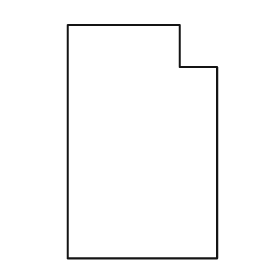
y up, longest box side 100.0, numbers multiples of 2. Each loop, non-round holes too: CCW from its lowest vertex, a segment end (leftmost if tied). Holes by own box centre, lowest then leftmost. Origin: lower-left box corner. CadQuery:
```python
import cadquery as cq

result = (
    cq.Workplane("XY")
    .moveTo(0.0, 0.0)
    .lineTo(64.0, 0.0)
    .lineTo(64.0, 82.0)
    .lineTo(48.0, 82.0)
    .lineTo(48.0, 100.0)
    .lineTo(0.0, 100.0)
    .close()
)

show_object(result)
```